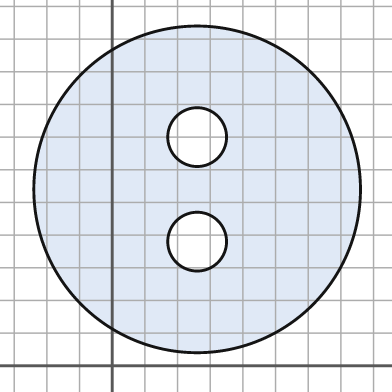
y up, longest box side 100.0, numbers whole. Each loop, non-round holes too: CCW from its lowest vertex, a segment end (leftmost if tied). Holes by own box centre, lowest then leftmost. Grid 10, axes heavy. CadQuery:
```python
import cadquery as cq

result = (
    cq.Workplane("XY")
    .moveTo(26.0, 54.0)
    .circle(50.0)
    .moveTo(26.0, 38.0)
    .circle(9.0)
    .moveTo(26.0, 70.0)
    .circle(9.0)
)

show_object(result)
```